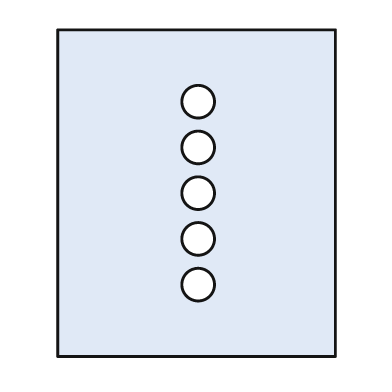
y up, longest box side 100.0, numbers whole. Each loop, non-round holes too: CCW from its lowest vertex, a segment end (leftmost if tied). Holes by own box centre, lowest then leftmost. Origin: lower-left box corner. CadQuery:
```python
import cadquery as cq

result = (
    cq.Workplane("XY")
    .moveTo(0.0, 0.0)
    .lineTo(85.0, 0.0)
    .lineTo(85.0, 100.0)
    .lineTo(0.0, 100.0)
    .close()
    .moveTo(43.0, 22.0)
    .circle(5.0)
    .moveTo(43.0, 36.0)
    .circle(5.0)
    .moveTo(43.0, 50.0)
    .circle(5.0)
    .moveTo(43.0, 64.0)
    .circle(5.0)
    .moveTo(43.0, 78.0)
    .circle(5.0)
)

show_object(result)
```